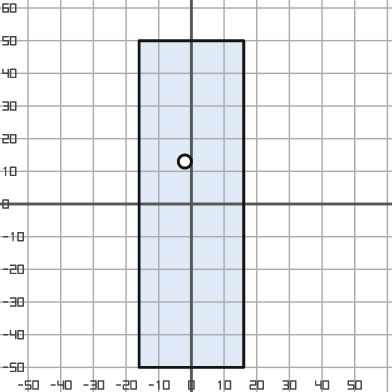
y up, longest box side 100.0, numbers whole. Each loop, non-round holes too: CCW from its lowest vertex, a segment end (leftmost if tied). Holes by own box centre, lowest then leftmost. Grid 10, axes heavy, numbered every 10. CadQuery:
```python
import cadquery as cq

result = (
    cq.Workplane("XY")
    .moveTo(-16.0, -50.0)
    .lineTo(16.0, -50.0)
    .lineTo(16.0, 50.0)
    .lineTo(-16.0, 50.0)
    .close()
    .moveTo(-2.0, 13.0)
    .circle(2.0)
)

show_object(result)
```